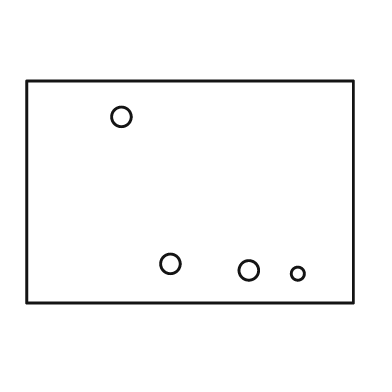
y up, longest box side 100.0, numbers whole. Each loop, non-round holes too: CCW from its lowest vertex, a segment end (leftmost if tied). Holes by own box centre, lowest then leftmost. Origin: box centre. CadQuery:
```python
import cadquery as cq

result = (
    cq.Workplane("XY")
    .moveTo(-50.0, -34.0)
    .lineTo(50.0, -34.0)
    .lineTo(50.0, 34.0)
    .lineTo(-50.0, 34.0)
    .close()
    .moveTo(33.0, -25.0)
    .circle(2.0)
    .moveTo(18.0, -24.0)
    .circle(3.0)
    .moveTo(-6.0, -22.0)
    .circle(3.0)
    .moveTo(-21.0, 23.0)
    .circle(3.0)
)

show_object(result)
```